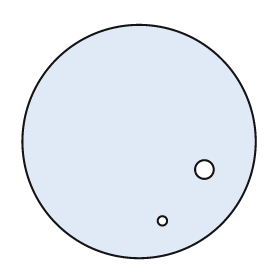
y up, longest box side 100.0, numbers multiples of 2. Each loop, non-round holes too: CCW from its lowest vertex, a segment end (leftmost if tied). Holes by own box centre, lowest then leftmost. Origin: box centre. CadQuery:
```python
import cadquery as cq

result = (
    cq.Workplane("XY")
    .moveTo(0.0, 0.0)
    .circle(50.0)
    .moveTo(10.0, -34.0)
    .circle(2.0)
    .moveTo(28.0, -12.0)
    .circle(4.0)
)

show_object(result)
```